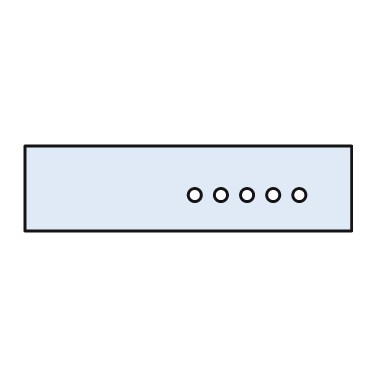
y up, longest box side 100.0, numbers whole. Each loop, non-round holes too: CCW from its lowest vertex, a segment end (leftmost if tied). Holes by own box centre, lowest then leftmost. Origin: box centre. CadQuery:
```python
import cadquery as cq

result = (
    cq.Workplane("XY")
    .moveTo(-50.0, -13.0)
    .lineTo(50.0, -13.0)
    .lineTo(50.0, 13.0)
    .lineTo(-50.0, 13.0)
    .close()
    .moveTo(2.0, -2.0)
    .circle(2.0)
    .moveTo(10.0, -2.0)
    .circle(2.0)
    .moveTo(18.0, -2.0)
    .circle(2.0)
    .moveTo(26.0, -2.0)
    .circle(2.0)
    .moveTo(34.0, -2.0)
    .circle(2.0)
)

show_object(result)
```